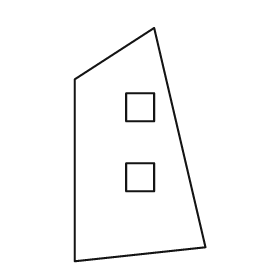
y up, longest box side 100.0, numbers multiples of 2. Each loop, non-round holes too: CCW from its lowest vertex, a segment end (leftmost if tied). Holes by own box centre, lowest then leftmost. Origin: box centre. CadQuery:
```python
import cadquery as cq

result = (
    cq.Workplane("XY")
    .moveTo(-28.0, -50.0)
    .lineTo(28.0, -44.0)
    .lineTo(6.0, 50.0)
    .lineTo(-28.0, 28.0)
    .close()
    .moveTo(-6.0, -20.0)
    .lineTo(6.0, -20.0)
    .lineTo(6.0, -8.0)
    .lineTo(-6.0, -8.0)
    .close()
    .moveTo(-6.0, 10.0)
    .lineTo(6.0, 10.0)
    .lineTo(6.0, 22.0)
    .lineTo(-6.0, 22.0)
    .close()
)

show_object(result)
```